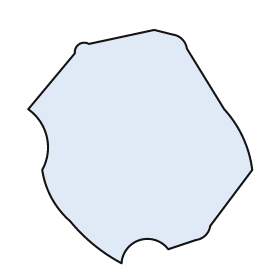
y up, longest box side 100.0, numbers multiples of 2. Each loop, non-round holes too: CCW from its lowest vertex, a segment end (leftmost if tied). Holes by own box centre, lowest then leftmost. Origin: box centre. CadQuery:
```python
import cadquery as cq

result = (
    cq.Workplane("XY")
    .moveTo(-8.0, -50.0)
    .threePointArc((0.0, -40.0), (12.0, -44.0))
    .lineTo(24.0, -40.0)
    .threePointArc((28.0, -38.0), (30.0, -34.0))
    .lineTo(48.0, -10.0)
    .threePointArc((44.0, 4.0), (36.0, 16.0))
    .lineTo(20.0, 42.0)
    .threePointArc((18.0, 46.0), (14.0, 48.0))
    .lineTo(6.0, 50.0)
    .lineTo(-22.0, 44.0)
    .threePointArc((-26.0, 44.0), (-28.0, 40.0))
    .lineTo(-48.0, 16.0)
    .threePointArc((-40.0, 4.0), (-42.0, -10.0))
    .threePointArc((-38.0, -22.0), (-30.0, -32.0))
    .threePointArc((-20.0, -42.0), (-8.0, -50.0))
    .close()
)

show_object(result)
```